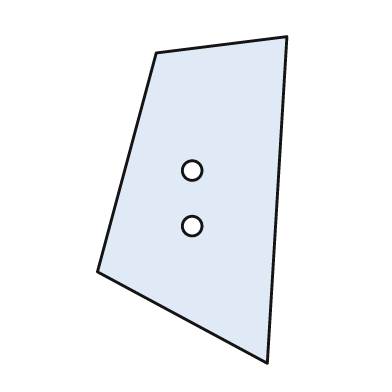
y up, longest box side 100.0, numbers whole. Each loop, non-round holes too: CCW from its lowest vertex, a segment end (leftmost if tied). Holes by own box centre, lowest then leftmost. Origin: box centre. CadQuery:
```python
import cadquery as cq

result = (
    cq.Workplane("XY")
    .moveTo(23.0, -50.0)
    .lineTo(29.0, 50.0)
    .lineTo(-11.0, 45.0)
    .lineTo(-29.0, -22.0)
    .close()
    .moveTo(0.0, -8.0)
    .circle(3.0)
    .moveTo(0.0, 9.0)
    .circle(3.0)
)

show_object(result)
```